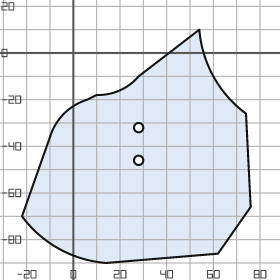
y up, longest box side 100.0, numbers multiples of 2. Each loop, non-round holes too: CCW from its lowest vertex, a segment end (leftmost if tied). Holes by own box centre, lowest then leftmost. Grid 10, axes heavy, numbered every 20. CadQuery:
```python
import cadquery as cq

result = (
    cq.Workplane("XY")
    .moveTo(14.0, -90.0)
    .lineTo(62.0, -86.0)
    .lineTo(76.0, -66.0)
    .lineTo(74.0, -26.0)
    .threePointArc((60.0, -10.0), (54.0, 10.0))
    .lineTo(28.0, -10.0)
    .threePointArc((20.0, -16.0), (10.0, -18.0))
    .lineTo(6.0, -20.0)
    .threePointArc((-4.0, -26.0), (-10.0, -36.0))
    .lineTo(-22.0, -70.0)
    .threePointArc((-6.0, -84.0), (14.0, -90.0))
    .close()
    .moveTo(28.0, -46.0)
    .circle(2.0)
    .moveTo(28.0, -32.0)
    .circle(2.0)
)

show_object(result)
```